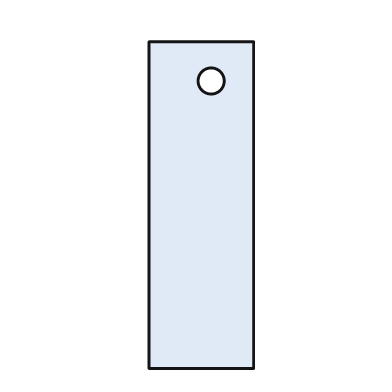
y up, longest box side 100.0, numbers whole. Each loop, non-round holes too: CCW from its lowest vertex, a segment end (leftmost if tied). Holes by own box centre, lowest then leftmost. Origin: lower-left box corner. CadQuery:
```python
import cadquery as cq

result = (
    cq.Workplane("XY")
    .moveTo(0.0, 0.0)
    .lineTo(32.0, 0.0)
    .lineTo(32.0, 100.0)
    .lineTo(0.0, 100.0)
    .close()
    .moveTo(19.0, 88.0)
    .circle(4.0)
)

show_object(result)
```